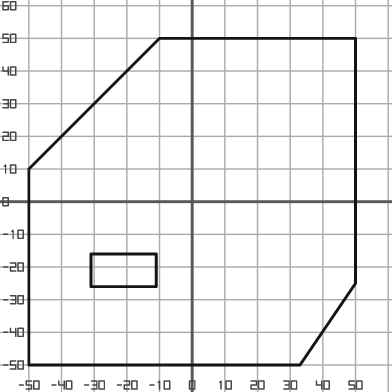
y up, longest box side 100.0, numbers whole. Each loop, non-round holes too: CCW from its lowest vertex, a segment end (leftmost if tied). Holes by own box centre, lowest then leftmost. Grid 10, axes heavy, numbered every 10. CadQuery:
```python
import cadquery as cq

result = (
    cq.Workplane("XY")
    .moveTo(-50.0, -50.0)
    .lineTo(33.0, -50.0)
    .lineTo(50.0, -25.0)
    .lineTo(50.0, 50.0)
    .lineTo(-10.0, 50.0)
    .lineTo(-50.0, 10.0)
    .close()
    .moveTo(-31.0, -26.0)
    .lineTo(-11.0, -26.0)
    .lineTo(-11.0, -16.0)
    .lineTo(-31.0, -16.0)
    .close()
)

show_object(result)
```